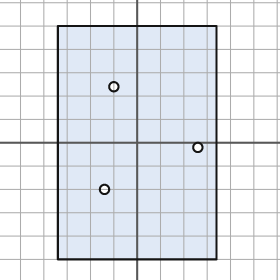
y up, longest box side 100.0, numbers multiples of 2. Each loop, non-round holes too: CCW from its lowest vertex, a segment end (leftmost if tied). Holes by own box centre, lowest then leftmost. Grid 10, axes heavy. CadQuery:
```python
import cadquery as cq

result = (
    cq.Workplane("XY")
    .moveTo(-34.0, -50.0)
    .lineTo(34.0, -50.0)
    .lineTo(34.0, 50.0)
    .lineTo(-34.0, 50.0)
    .close()
    .moveTo(-14.0, -20.0)
    .circle(2.0)
    .moveTo(26.0, -2.0)
    .circle(2.0)
    .moveTo(-10.0, 24.0)
    .circle(2.0)
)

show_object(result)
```